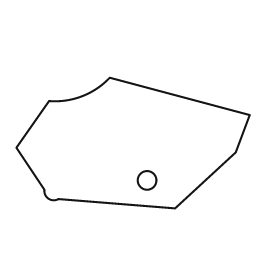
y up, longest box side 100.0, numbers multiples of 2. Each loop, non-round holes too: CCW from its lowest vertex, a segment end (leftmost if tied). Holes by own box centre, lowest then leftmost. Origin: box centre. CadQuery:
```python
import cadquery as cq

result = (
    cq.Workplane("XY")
    .moveTo(18.0, -28.0)
    .lineTo(44.0, -4.0)
    .lineTo(50.0, 12.0)
    .lineTo(-10.0, 28.0)
    .threePointArc((-22.0, 20.0), (-36.0, 18.0))
    .lineTo(-50.0, -2.0)
    .lineTo(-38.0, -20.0)
    .threePointArc((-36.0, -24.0), (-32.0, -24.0))
    .close()
    .moveTo(6.0, -16.0)
    .circle(4.0)
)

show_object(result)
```